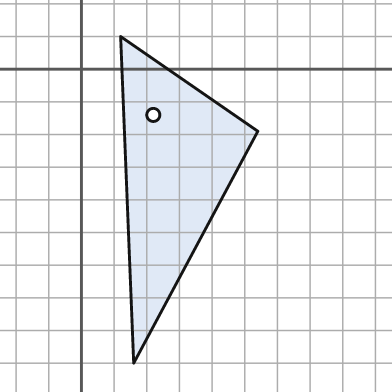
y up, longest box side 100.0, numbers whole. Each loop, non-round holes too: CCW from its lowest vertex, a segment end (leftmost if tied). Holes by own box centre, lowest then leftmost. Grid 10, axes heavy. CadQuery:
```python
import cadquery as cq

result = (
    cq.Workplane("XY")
    .moveTo(16.0, -90.0)
    .lineTo(54.0, -19.0)
    .lineTo(12.0, 10.0)
    .close()
    .moveTo(22.0, -14.0)
    .circle(2.0)
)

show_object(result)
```